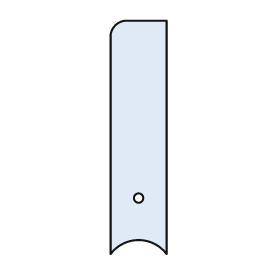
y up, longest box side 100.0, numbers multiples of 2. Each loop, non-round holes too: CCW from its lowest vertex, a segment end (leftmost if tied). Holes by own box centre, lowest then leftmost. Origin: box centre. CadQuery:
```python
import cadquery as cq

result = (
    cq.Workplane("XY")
    .moveTo(-12.0, -50.0)
    .threePointArc((0.0, -44.0), (12.0, -50.0))
    .lineTo(12.0, 50.0)
    .lineTo(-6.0, 50.0)
    .threePointArc((-10.0, 48.0), (-12.0, 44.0))
    .close()
    .moveTo(0.0, -26.0)
    .circle(2.0)
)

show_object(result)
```